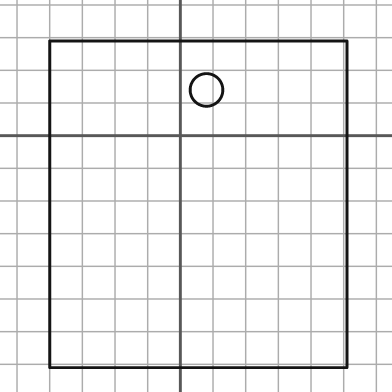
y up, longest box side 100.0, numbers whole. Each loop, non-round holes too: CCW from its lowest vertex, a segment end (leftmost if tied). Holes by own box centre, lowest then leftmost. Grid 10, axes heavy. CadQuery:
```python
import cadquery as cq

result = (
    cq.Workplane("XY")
    .moveTo(-40.0, -71.0)
    .lineTo(51.0, -71.0)
    .lineTo(51.0, 29.0)
    .lineTo(-40.0, 29.0)
    .close()
    .moveTo(8.0, 14.0)
    .circle(5.0)
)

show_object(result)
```